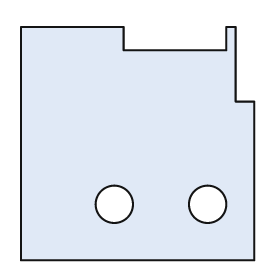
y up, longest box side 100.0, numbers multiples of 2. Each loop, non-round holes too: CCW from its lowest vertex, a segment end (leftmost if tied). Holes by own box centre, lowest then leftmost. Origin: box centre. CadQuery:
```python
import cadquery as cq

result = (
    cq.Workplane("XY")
    .moveTo(-50.0, -50.0)
    .lineTo(50.0, -50.0)
    .lineTo(50.0, 18.0)
    .lineTo(42.0, 18.0)
    .lineTo(42.0, 50.0)
    .lineTo(38.0, 50.0)
    .lineTo(38.0, 40.0)
    .lineTo(-6.0, 40.0)
    .lineTo(-6.0, 50.0)
    .lineTo(-50.0, 50.0)
    .close()
    .moveTo(-10.0, -26.0)
    .circle(8.0)
    .moveTo(30.0, -26.0)
    .circle(8.0)
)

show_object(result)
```